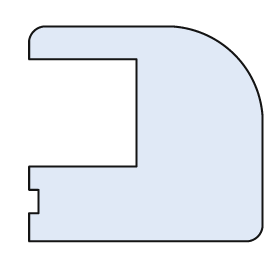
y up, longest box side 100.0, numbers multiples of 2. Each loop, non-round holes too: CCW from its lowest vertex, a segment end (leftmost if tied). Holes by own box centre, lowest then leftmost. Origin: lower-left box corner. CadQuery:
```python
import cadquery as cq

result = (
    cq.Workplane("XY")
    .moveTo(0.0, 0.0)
    .lineTo(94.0, 0.0)
    .threePointArc((98.0, 2.0), (100.0, 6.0))
    .lineTo(100.0, 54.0)
    .threePointArc((88.0, 80.0), (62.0, 92.0))
    .lineTo(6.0, 92.0)
    .threePointArc((2.0, 90.0), (0.0, 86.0))
    .lineTo(0.0, 78.0)
    .lineTo(46.0, 78.0)
    .lineTo(46.0, 32.0)
    .lineTo(0.0, 32.0)
    .lineTo(0.0, 22.0)
    .lineTo(4.0, 22.0)
    .lineTo(4.0, 12.0)
    .lineTo(0.0, 12.0)
    .close()
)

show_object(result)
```